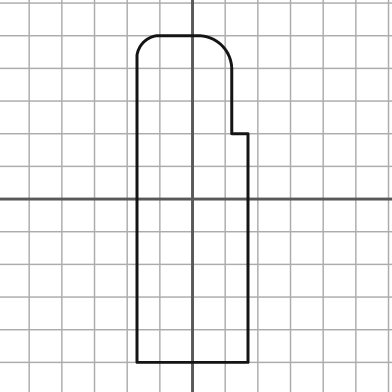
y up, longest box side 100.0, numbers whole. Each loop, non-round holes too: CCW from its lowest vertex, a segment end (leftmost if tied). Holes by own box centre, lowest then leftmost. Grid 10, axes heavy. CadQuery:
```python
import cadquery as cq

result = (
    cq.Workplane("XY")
    .moveTo(-17.0, -50.0)
    .lineTo(17.0, -50.0)
    .lineTo(17.0, 20.0)
    .lineTo(12.0, 20.0)
    .lineTo(12.0, 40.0)
    .threePointArc((9.0, 47.0), (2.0, 50.0))
    .lineTo(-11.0, 50.0)
    .threePointArc((-15.0, 48.0), (-17.0, 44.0))
    .close()
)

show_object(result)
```